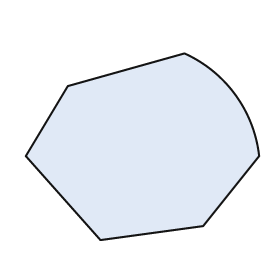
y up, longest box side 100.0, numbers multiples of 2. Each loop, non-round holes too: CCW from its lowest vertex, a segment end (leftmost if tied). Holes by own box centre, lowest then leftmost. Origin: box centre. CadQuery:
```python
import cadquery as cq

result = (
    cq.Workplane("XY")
    .moveTo(-18.0, -40.0)
    .lineTo(26.0, -34.0)
    .lineTo(50.0, -4.0)
    .threePointArc((40.0, 22.0), (18.0, 40.0))
    .lineTo(-32.0, 26.0)
    .lineTo(-50.0, -4.0)
    .close()
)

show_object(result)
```